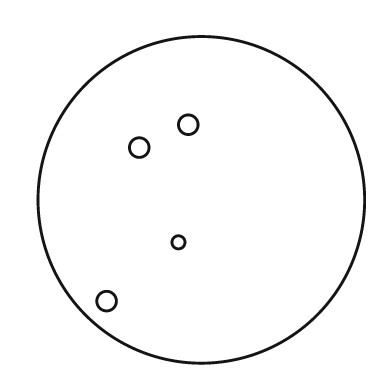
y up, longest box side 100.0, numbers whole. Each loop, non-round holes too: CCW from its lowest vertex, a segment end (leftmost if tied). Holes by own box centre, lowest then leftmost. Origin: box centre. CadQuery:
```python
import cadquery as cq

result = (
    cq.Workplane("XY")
    .moveTo(0.0, 0.0)
    .circle(50.0)
    .moveTo(-29.0, -31.0)
    .circle(3.0)
    .moveTo(-7.0, -13.0)
    .circle(2.0)
    .moveTo(-19.0, 16.0)
    .circle(3.0)
    .moveTo(-4.0, 23.0)
    .circle(3.0)
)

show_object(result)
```